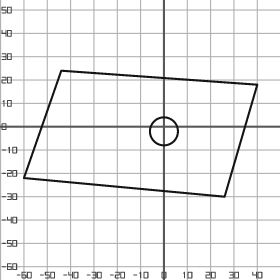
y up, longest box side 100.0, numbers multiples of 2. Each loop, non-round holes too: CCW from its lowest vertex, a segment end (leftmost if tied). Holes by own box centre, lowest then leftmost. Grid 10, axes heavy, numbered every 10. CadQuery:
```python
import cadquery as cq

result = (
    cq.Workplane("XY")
    .moveTo(26.0, -30.0)
    .lineTo(40.0, 18.0)
    .lineTo(-44.0, 24.0)
    .lineTo(-60.0, -22.0)
    .close()
    .moveTo(0.0, -2.0)
    .circle(6.0)
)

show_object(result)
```